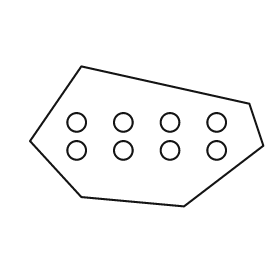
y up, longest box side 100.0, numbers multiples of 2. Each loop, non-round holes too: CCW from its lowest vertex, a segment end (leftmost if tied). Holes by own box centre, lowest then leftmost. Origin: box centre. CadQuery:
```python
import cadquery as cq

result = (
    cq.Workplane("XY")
    .moveTo(16.0, -30.0)
    .lineTo(50.0, -4.0)
    .lineTo(44.0, 14.0)
    .lineTo(-28.0, 30.0)
    .lineTo(-50.0, -2.0)
    .lineTo(-28.0, -26.0)
    .close()
    .moveTo(-30.0, -6.0)
    .circle(4.0)
    .moveTo(-10.0, -6.0)
    .circle(4.0)
    .moveTo(10.0, -6.0)
    .circle(4.0)
    .moveTo(30.0, -6.0)
    .circle(4.0)
    .moveTo(-30.0, 6.0)
    .circle(4.0)
    .moveTo(-10.0, 6.0)
    .circle(4.0)
    .moveTo(10.0, 6.0)
    .circle(4.0)
    .moveTo(30.0, 6.0)
    .circle(4.0)
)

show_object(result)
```